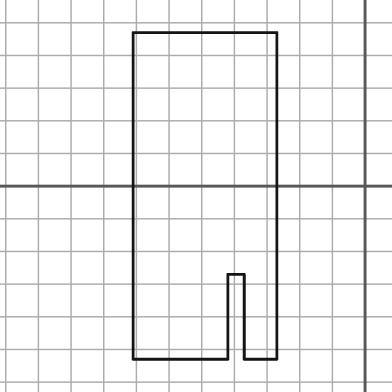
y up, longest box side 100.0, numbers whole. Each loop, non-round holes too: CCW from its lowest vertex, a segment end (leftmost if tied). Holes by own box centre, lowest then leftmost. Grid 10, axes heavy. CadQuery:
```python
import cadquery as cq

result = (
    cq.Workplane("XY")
    .moveTo(-71.0, -53.0)
    .lineTo(-42.0, -53.0)
    .lineTo(-42.0, -27.0)
    .lineTo(-37.0, -27.0)
    .lineTo(-37.0, -53.0)
    .lineTo(-27.0, -53.0)
    .lineTo(-27.0, 47.0)
    .lineTo(-71.0, 47.0)
    .close()
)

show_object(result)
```